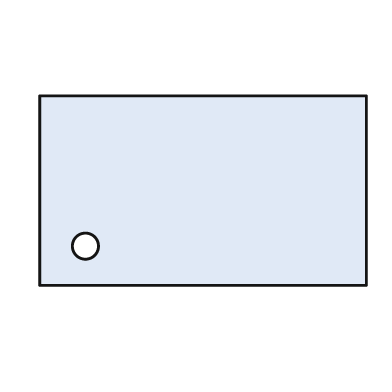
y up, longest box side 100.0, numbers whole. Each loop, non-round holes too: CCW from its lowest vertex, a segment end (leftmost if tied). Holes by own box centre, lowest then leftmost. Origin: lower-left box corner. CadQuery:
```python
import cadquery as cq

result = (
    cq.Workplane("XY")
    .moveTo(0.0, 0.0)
    .lineTo(100.0, 0.0)
    .lineTo(100.0, 58.0)
    .lineTo(0.0, 58.0)
    .close()
    .moveTo(14.0, 12.0)
    .circle(4.0)
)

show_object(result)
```